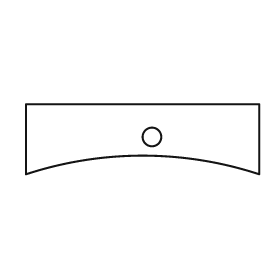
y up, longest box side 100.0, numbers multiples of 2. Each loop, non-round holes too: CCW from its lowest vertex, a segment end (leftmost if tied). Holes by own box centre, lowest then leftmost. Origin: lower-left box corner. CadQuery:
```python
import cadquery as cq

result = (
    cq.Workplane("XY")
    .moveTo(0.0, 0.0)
    .threePointArc((50.0, 8.0), (100.0, 0.0))
    .lineTo(100.0, 30.0)
    .lineTo(0.0, 30.0)
    .close()
    .moveTo(54.0, 16.0)
    .circle(4.0)
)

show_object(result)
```